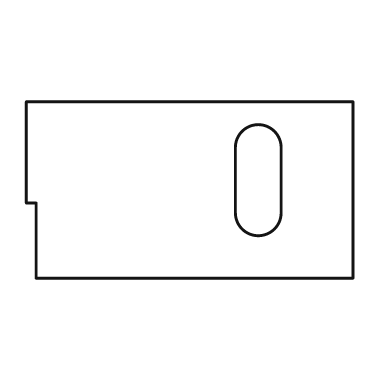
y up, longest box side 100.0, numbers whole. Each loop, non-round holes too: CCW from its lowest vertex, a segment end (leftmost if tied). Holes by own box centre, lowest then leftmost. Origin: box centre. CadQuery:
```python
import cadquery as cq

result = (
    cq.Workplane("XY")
    .moveTo(-47.0, -27.0)
    .lineTo(50.0, -27.0)
    .lineTo(50.0, 27.0)
    .lineTo(-50.0, 27.0)
    .lineTo(-50.0, -4.0)
    .lineTo(-47.0, -4.0)
    .close()
    .moveTo(14.0, -7.0)
    .threePointArc((21.0, -14.0), (28.0, -7.0))
    .lineTo(28.0, 13.0)
    .threePointArc((21.0, 20.0), (14.0, 13.0))
    .close()
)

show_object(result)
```